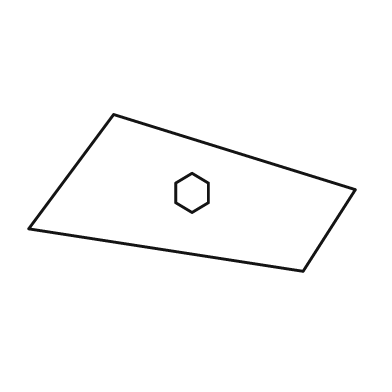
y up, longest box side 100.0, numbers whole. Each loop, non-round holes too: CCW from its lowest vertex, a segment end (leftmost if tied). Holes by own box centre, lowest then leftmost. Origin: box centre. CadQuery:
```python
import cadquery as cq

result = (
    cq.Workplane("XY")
    .moveTo(34.0, -24.0)
    .lineTo(50.0, 1.0)
    .lineTo(-24.0, 24.0)
    .lineTo(-50.0, -11.0)
    .close()
    .moveTo(0.0, -6.0)
    .lineTo(5.0, -3.0)
    .lineTo(5.0, 3.0)
    .lineTo(0.0, 6.0)
    .lineTo(-5.0, 3.0)
    .lineTo(-5.0, -3.0)
    .close()
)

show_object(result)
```